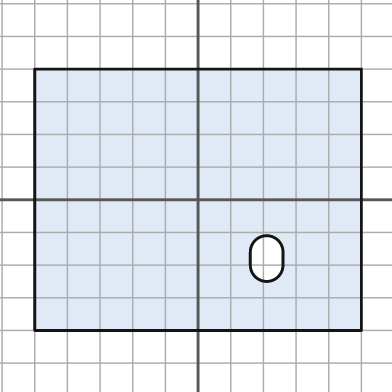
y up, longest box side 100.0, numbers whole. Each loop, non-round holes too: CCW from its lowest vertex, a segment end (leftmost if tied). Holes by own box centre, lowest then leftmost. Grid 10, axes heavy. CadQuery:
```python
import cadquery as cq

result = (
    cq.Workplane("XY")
    .moveTo(-50.0, -40.0)
    .lineTo(50.0, -40.0)
    .lineTo(50.0, 40.0)
    .lineTo(-50.0, 40.0)
    .close()
    .moveTo(16.0, -20.0)
    .threePointArc((21.0, -25.0), (26.0, -20.0))
    .lineTo(26.0, -16.0)
    .threePointArc((21.0, -11.0), (16.0, -16.0))
    .close()
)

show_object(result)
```